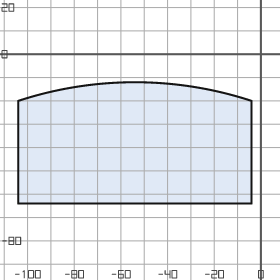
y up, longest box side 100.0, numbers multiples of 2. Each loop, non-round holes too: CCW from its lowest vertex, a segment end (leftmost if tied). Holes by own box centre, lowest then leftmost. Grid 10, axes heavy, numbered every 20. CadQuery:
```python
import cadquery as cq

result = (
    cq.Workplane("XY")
    .moveTo(-104.0, -64.0)
    .lineTo(-4.0, -64.0)
    .lineTo(-4.0, -20.0)
    .threePointArc((-54.0, -12.0), (-104.0, -20.0))
    .close()
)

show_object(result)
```